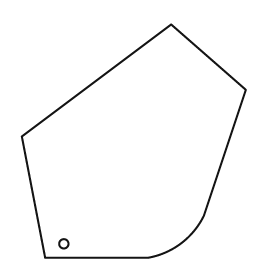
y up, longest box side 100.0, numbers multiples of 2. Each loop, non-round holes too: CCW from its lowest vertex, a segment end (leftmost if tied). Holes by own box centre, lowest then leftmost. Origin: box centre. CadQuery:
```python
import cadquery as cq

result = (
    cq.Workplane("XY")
    .moveTo(-38.0, -50.0)
    .lineTo(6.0, -50.0)
    .threePointArc((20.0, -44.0), (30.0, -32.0))
    .lineTo(48.0, 22.0)
    .lineTo(16.0, 50.0)
    .lineTo(-48.0, 2.0)
    .close()
    .moveTo(-30.0, -44.0)
    .circle(2.0)
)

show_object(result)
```